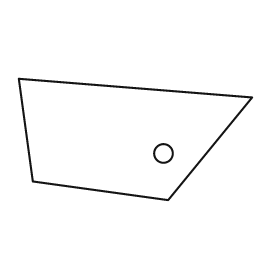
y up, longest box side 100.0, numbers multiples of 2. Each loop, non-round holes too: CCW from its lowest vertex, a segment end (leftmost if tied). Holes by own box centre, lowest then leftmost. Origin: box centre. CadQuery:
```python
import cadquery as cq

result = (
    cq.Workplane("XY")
    .moveTo(14.0, -26.0)
    .lineTo(50.0, 18.0)
    .lineTo(-50.0, 26.0)
    .lineTo(-44.0, -18.0)
    .close()
    .moveTo(12.0, -6.0)
    .circle(4.0)
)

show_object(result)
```